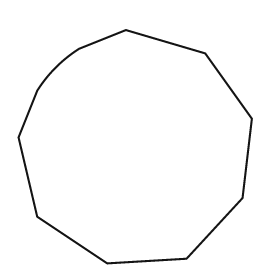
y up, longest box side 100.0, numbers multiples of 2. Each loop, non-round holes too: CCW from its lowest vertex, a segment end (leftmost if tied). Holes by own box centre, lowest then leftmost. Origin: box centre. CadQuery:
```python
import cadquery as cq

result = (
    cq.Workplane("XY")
    .moveTo(-12.0, -50.0)
    .lineTo(22.0, -48.0)
    .lineTo(46.0, -22.0)
    .lineTo(50.0, 12.0)
    .lineTo(30.0, 40.0)
    .lineTo(-4.0, 50.0)
    .lineTo(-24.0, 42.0)
    .threePointArc((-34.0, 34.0), (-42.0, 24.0))
    .lineTo(-50.0, 4.0)
    .lineTo(-42.0, -30.0)
    .close()
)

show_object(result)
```